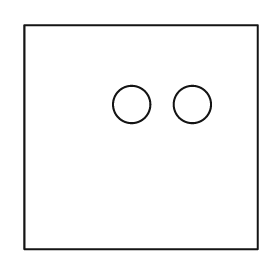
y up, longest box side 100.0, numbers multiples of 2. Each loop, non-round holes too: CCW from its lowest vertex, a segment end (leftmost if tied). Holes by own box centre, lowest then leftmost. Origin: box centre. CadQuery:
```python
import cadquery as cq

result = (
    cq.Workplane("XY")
    .moveTo(-50.0, -48.0)
    .lineTo(50.0, -48.0)
    .lineTo(50.0, 48.0)
    .lineTo(-50.0, 48.0)
    .close()
    .moveTo(-4.0, 14.0)
    .circle(8.0)
    .moveTo(22.0, 14.0)
    .circle(8.0)
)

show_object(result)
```